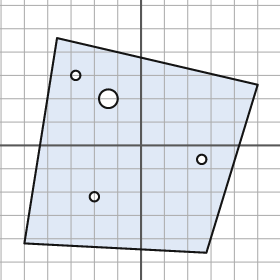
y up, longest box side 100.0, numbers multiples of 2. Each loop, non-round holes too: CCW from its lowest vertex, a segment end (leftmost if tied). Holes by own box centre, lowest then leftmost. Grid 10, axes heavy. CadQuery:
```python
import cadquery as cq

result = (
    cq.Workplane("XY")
    .moveTo(28.0, -46.0)
    .lineTo(50.0, 26.0)
    .lineTo(-36.0, 46.0)
    .lineTo(-50.0, -42.0)
    .close()
    .moveTo(-20.0, -22.0)
    .circle(2.0)
    .moveTo(26.0, -6.0)
    .circle(2.0)
    .moveTo(-14.0, 20.0)
    .circle(4.0)
    .moveTo(-28.0, 30.0)
    .circle(2.0)
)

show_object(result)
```